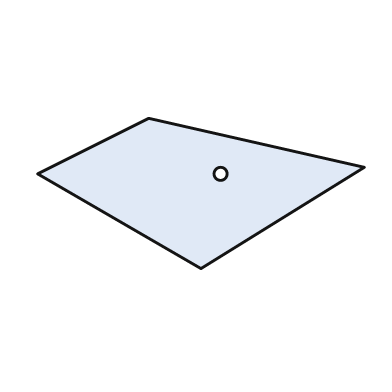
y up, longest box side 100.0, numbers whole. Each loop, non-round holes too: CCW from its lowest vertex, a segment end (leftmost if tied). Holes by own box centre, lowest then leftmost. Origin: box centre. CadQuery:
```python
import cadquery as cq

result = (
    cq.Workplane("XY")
    .moveTo(0.0, -23.0)
    .lineTo(50.0, 8.0)
    .lineTo(-16.0, 23.0)
    .lineTo(-50.0, 6.0)
    .close()
    .moveTo(6.0, 6.0)
    .circle(2.0)
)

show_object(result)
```